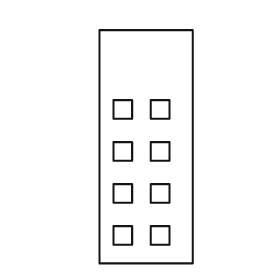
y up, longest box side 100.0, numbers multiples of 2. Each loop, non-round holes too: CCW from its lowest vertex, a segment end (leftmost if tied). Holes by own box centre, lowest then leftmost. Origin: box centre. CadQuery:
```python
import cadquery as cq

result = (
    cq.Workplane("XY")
    .moveTo(-20.0, -50.0)
    .lineTo(20.0, -50.0)
    .lineTo(20.0, 50.0)
    .lineTo(-20.0, 50.0)
    .close()
    .moveTo(-14.0, -42.0)
    .lineTo(-6.0, -42.0)
    .lineTo(-6.0, -34.0)
    .lineTo(-14.0, -34.0)
    .close()
    .moveTo(2.0, -42.0)
    .lineTo(10.0, -42.0)
    .lineTo(10.0, -34.0)
    .lineTo(2.0, -34.0)
    .close()
    .moveTo(-14.0, -24.0)
    .lineTo(-6.0, -24.0)
    .lineTo(-6.0, -16.0)
    .lineTo(-14.0, -16.0)
    .close()
    .moveTo(2.0, -24.0)
    .lineTo(10.0, -24.0)
    .lineTo(10.0, -16.0)
    .lineTo(2.0, -16.0)
    .close()
    .moveTo(-14.0, -6.0)
    .lineTo(-6.0, -6.0)
    .lineTo(-6.0, 2.0)
    .lineTo(-14.0, 2.0)
    .close()
    .moveTo(2.0, -6.0)
    .lineTo(10.0, -6.0)
    .lineTo(10.0, 2.0)
    .lineTo(2.0, 2.0)
    .close()
    .moveTo(-14.0, 12.0)
    .lineTo(-6.0, 12.0)
    .lineTo(-6.0, 20.0)
    .lineTo(-14.0, 20.0)
    .close()
    .moveTo(2.0, 12.0)
    .lineTo(10.0, 12.0)
    .lineTo(10.0, 20.0)
    .lineTo(2.0, 20.0)
    .close()
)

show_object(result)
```